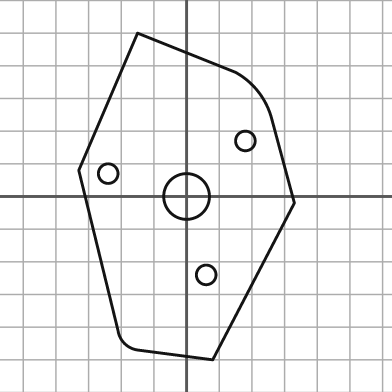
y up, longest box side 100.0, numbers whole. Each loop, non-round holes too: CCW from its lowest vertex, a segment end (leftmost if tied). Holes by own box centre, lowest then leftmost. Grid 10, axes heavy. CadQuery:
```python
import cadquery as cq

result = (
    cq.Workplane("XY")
    .moveTo(8.0, -50.0)
    .lineTo(33.0, -2.0)
    .lineTo(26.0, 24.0)
    .threePointArc((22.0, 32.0), (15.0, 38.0))
    .lineTo(-15.0, 50.0)
    .lineTo(-33.0, 8.0)
    .lineTo(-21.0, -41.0)
    .threePointArc((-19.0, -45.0), (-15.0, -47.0))
    .close()
    .moveTo(6.0, -24.0)
    .circle(3.0)
    .moveTo(0.0, 0.0)
    .circle(7.0)
    .moveTo(-24.0, 7.0)
    .circle(3.0)
    .moveTo(18.0, 17.0)
    .circle(3.0)
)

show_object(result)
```